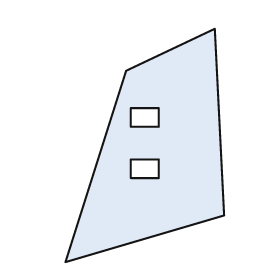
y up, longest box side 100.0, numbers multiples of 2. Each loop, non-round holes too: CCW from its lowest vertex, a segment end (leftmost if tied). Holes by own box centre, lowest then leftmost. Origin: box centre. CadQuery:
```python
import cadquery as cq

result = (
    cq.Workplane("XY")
    .moveTo(-34.0, -50.0)
    .lineTo(34.0, -30.0)
    .lineTo(30.0, 50.0)
    .lineTo(-8.0, 32.0)
    .close()
    .moveTo(-6.0, -14.0)
    .lineTo(6.0, -14.0)
    .lineTo(6.0, -6.0)
    .lineTo(-6.0, -6.0)
    .close()
    .moveTo(-6.0, 8.0)
    .lineTo(6.0, 8.0)
    .lineTo(6.0, 16.0)
    .lineTo(-6.0, 16.0)
    .close()
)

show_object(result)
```